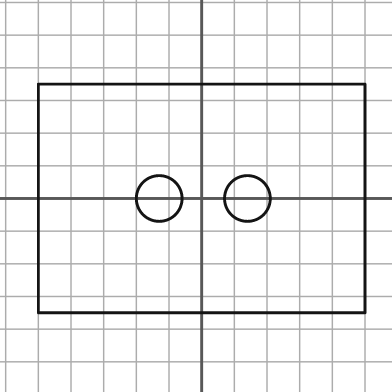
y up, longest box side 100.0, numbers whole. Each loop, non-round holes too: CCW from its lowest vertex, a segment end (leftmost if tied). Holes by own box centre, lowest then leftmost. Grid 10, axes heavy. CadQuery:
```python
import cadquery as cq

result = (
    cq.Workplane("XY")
    .moveTo(-50.0, -35.0)
    .lineTo(50.0, -35.0)
    .lineTo(50.0, 35.0)
    .lineTo(-50.0, 35.0)
    .close()
    .moveTo(-13.0, 0.0)
    .circle(7.0)
    .moveTo(14.0, 0.0)
    .circle(7.0)
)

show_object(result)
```